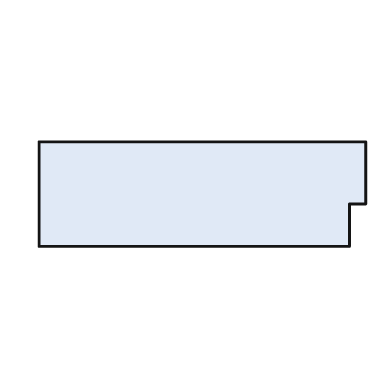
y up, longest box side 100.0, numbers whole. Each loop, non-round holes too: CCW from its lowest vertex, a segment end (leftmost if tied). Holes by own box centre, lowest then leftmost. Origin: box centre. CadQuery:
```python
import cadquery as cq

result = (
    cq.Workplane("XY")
    .moveTo(-50.0, -16.0)
    .lineTo(45.0, -16.0)
    .lineTo(45.0, -3.0)
    .lineTo(50.0, -3.0)
    .lineTo(50.0, 16.0)
    .lineTo(-50.0, 16.0)
    .close()
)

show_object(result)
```